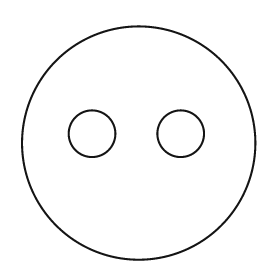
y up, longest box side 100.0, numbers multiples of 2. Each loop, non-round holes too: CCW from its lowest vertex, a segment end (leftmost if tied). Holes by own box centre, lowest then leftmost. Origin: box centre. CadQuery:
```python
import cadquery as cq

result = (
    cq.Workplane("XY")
    .moveTo(0.0, 0.0)
    .circle(50.0)
    .moveTo(-20.0, 4.0)
    .circle(10.0)
    .moveTo(18.0, 4.0)
    .circle(10.0)
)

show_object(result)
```